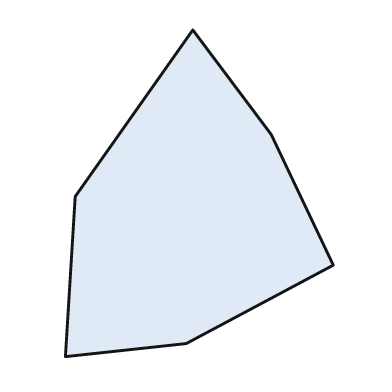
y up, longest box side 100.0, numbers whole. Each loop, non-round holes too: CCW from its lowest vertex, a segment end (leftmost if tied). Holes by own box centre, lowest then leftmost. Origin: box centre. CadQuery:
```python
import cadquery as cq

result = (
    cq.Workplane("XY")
    .moveTo(-41.0, -50.0)
    .lineTo(-4.0, -46.0)
    .lineTo(41.0, -22.0)
    .lineTo(22.0, 18.0)
    .lineTo(-2.0, 50.0)
    .lineTo(-38.0, -1.0)
    .close()
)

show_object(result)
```